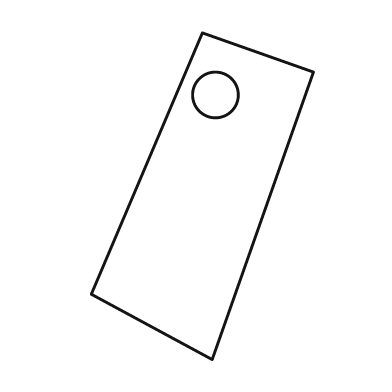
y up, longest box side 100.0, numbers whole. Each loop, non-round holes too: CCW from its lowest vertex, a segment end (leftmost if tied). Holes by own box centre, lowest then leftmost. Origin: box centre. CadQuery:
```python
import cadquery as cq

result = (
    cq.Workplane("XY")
    .moveTo(3.0, -50.0)
    .lineTo(34.0, 38.0)
    .lineTo(0.0, 50.0)
    .lineTo(-34.0, -30.0)
    .close()
    .moveTo(4.0, 31.0)
    .circle(7.0)
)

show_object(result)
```